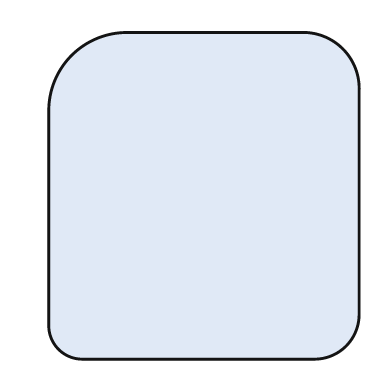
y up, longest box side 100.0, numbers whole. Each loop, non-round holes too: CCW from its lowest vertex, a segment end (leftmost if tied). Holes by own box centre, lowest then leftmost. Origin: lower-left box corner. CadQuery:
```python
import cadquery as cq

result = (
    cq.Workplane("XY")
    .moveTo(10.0, 0.0)
    .lineTo(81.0, 0.0)
    .threePointArc((91.0, 4.0), (95.0, 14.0))
    .lineTo(95.0, 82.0)
    .threePointArc((90.0, 95.0), (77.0, 100.0))
    .lineTo(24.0, 100.0)
    .threePointArc((7.0, 93.0), (0.0, 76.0))
    .lineTo(0.0, 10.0)
    .threePointArc((3.0, 3.0), (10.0, 0.0))
    .close()
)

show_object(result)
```